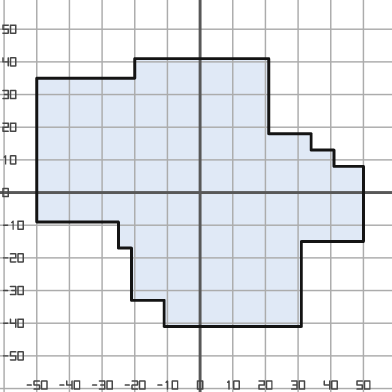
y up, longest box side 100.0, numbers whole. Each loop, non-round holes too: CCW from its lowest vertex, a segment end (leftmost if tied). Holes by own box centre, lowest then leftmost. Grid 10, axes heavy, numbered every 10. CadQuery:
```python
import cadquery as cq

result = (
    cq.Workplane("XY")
    .moveTo(-11.0, -41.0)
    .lineTo(31.0, -41.0)
    .lineTo(31.0, -15.0)
    .lineTo(50.0, -15.0)
    .lineTo(50.0, 8.0)
    .lineTo(41.0, 8.0)
    .lineTo(41.0, 13.0)
    .lineTo(34.0, 13.0)
    .lineTo(34.0, 18.0)
    .lineTo(21.0, 18.0)
    .lineTo(21.0, 41.0)
    .lineTo(-20.0, 41.0)
    .lineTo(-20.0, 35.0)
    .lineTo(-50.0, 35.0)
    .lineTo(-50.0, -9.0)
    .lineTo(-25.0, -9.0)
    .lineTo(-25.0, -17.0)
    .lineTo(-21.0, -17.0)
    .lineTo(-21.0, -33.0)
    .lineTo(-11.0, -33.0)
    .close()
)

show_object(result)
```